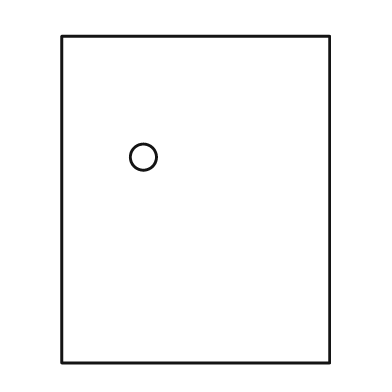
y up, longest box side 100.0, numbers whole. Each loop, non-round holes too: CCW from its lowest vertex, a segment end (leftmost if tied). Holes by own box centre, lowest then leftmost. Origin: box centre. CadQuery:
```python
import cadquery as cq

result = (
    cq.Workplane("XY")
    .moveTo(-41.0, -50.0)
    .lineTo(41.0, -50.0)
    .lineTo(41.0, 50.0)
    .lineTo(-41.0, 50.0)
    .close()
    .moveTo(-16.0, 13.0)
    .circle(4.0)
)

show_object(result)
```